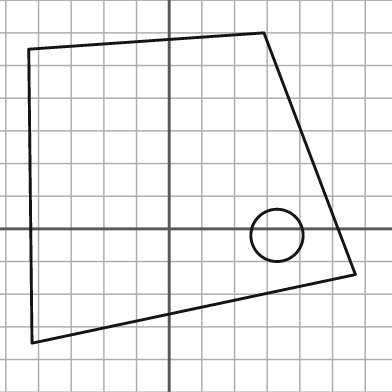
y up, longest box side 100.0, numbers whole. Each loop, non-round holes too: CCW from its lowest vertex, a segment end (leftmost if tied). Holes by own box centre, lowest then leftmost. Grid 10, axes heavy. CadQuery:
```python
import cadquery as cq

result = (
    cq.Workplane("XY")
    .moveTo(-42.0, -35.0)
    .lineTo(57.0, -14.0)
    .lineTo(29.0, 60.0)
    .lineTo(-43.0, 55.0)
    .close()
    .moveTo(33.0, -2.0)
    .circle(8.0)
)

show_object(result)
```